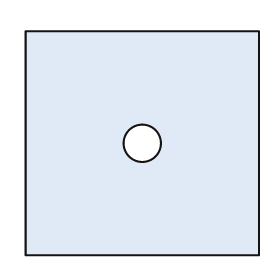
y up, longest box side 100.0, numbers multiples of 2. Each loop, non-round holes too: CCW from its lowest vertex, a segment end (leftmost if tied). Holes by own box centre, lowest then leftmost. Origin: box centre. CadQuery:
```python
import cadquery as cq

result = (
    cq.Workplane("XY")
    .moveTo(-50.0, -48.0)
    .lineTo(50.0, -48.0)
    .lineTo(50.0, 48.0)
    .lineTo(-50.0, 48.0)
    .close()
    .moveTo(0.0, 0.0)
    .circle(8.0)
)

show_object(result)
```